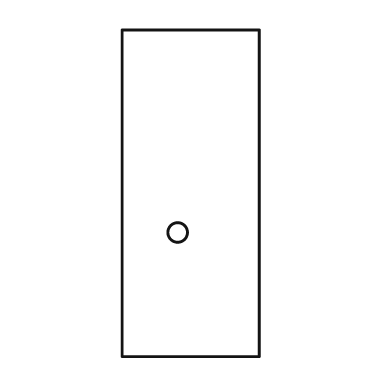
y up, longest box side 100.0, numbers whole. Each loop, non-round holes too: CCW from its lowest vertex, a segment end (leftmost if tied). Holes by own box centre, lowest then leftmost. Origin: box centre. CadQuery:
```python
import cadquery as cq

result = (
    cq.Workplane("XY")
    .moveTo(-21.0, -50.0)
    .lineTo(21.0, -50.0)
    .lineTo(21.0, 50.0)
    .lineTo(-21.0, 50.0)
    .close()
    .moveTo(-4.0, -12.0)
    .circle(3.0)
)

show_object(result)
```